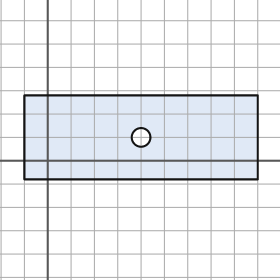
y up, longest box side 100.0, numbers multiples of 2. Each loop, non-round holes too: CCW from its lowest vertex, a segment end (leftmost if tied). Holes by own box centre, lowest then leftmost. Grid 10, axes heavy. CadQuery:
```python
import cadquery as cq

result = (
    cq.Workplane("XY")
    .moveTo(-10.0, -8.0)
    .lineTo(90.0, -8.0)
    .lineTo(90.0, 28.0)
    .lineTo(-10.0, 28.0)
    .close()
    .moveTo(40.0, 10.0)
    .circle(4.0)
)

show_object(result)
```